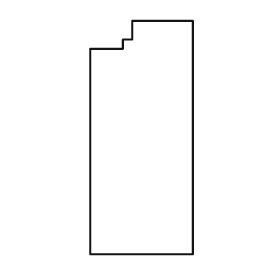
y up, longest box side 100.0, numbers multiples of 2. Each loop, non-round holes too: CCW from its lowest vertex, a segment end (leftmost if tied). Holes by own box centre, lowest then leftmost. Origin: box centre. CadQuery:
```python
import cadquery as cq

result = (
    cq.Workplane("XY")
    .moveTo(-22.0, -50.0)
    .lineTo(22.0, -50.0)
    .lineTo(22.0, 50.0)
    .lineTo(-4.0, 50.0)
    .lineTo(-4.0, 42.0)
    .lineTo(-8.0, 42.0)
    .lineTo(-8.0, 38.0)
    .lineTo(-22.0, 38.0)
    .close()
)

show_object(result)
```